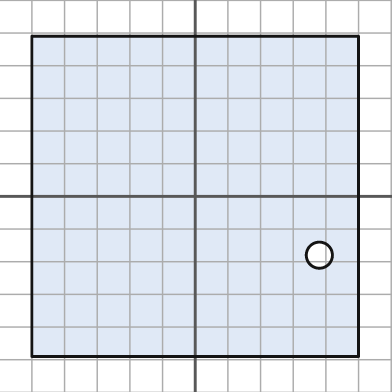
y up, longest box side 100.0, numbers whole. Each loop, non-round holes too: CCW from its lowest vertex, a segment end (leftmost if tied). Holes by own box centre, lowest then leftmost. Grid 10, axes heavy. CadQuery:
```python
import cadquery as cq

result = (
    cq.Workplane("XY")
    .moveTo(-50.0, -49.0)
    .lineTo(50.0, -49.0)
    .lineTo(50.0, 49.0)
    .lineTo(-50.0, 49.0)
    .close()
    .moveTo(38.0, -18.0)
    .circle(4.0)
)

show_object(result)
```